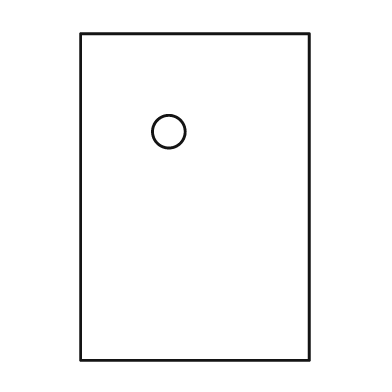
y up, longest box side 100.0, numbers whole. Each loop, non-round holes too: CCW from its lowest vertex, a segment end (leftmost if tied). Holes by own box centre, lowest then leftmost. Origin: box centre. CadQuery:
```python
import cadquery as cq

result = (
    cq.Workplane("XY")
    .moveTo(-35.0, -50.0)
    .lineTo(35.0, -50.0)
    .lineTo(35.0, 50.0)
    .lineTo(-35.0, 50.0)
    .close()
    .moveTo(-8.0, 20.0)
    .circle(5.0)
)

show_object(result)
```